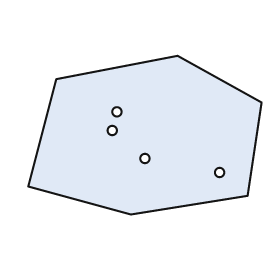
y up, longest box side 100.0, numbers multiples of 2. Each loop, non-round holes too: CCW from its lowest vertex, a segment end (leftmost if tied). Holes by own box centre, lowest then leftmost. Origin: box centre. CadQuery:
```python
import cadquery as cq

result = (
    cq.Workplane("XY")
    .moveTo(-6.0, -34.0)
    .lineTo(44.0, -26.0)
    .lineTo(50.0, 14.0)
    .lineTo(14.0, 34.0)
    .lineTo(-38.0, 24.0)
    .lineTo(-50.0, -22.0)
    .close()
    .moveTo(32.0, -16.0)
    .circle(2.0)
    .moveTo(0.0, -10.0)
    .circle(2.0)
    .moveTo(-14.0, 2.0)
    .circle(2.0)
    .moveTo(-12.0, 10.0)
    .circle(2.0)
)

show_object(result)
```